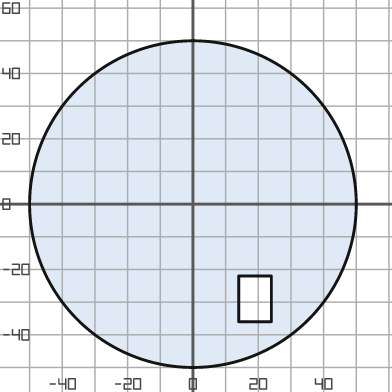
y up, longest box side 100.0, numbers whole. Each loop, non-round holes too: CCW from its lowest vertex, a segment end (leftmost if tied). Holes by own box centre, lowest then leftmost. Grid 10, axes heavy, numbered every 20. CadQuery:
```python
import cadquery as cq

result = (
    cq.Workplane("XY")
    .moveTo(0.0, 0.0)
    .circle(50.0)
    .moveTo(14.0, -36.0)
    .lineTo(24.0, -36.0)
    .lineTo(24.0, -22.0)
    .lineTo(14.0, -22.0)
    .close()
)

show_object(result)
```